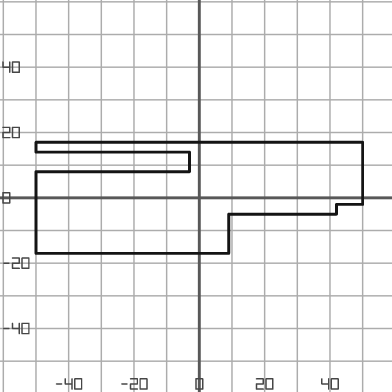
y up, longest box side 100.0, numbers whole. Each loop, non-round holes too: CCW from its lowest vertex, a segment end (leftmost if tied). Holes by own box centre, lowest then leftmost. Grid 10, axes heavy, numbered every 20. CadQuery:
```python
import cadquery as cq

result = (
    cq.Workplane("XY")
    .moveTo(-50.0, -17.0)
    .lineTo(9.0, -17.0)
    .lineTo(9.0, -5.0)
    .lineTo(42.0, -5.0)
    .lineTo(42.0, -2.0)
    .lineTo(50.0, -2.0)
    .lineTo(50.0, 17.0)
    .lineTo(-50.0, 17.0)
    .lineTo(-50.0, 14.0)
    .lineTo(-3.0, 14.0)
    .lineTo(-3.0, 8.0)
    .lineTo(-50.0, 8.0)
    .close()
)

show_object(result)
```